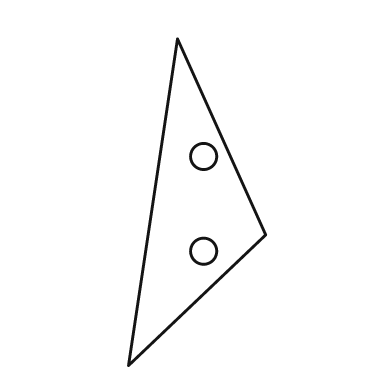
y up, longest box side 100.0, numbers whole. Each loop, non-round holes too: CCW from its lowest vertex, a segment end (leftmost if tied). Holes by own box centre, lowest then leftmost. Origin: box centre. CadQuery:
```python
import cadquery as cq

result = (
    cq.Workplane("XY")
    .moveTo(-21.0, -50.0)
    .lineTo(21.0, -10.0)
    .lineTo(-6.0, 50.0)
    .close()
    .moveTo(2.0, -15.0)
    .circle(4.0)
    .moveTo(2.0, 14.0)
    .circle(4.0)
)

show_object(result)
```